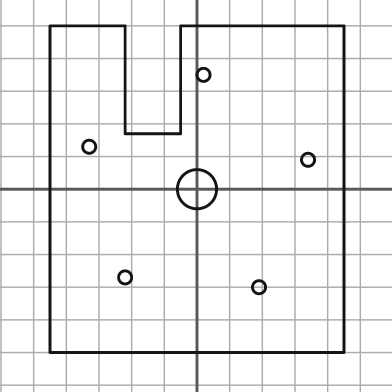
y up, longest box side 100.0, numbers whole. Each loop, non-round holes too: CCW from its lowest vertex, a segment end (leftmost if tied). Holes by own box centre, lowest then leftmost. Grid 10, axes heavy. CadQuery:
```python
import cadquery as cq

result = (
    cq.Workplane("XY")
    .moveTo(-45.0, -50.0)
    .lineTo(45.0, -50.0)
    .lineTo(45.0, 50.0)
    .lineTo(-5.0, 50.0)
    .lineTo(-5.0, 17.0)
    .lineTo(-22.0, 17.0)
    .lineTo(-22.0, 50.0)
    .lineTo(-45.0, 50.0)
    .close()
    .moveTo(19.0, -30.0)
    .circle(2.0)
    .moveTo(-22.0, -27.0)
    .circle(2.0)
    .moveTo(0.0, 0.0)
    .circle(6.0)
    .moveTo(34.0, 9.0)
    .circle(2.0)
    .moveTo(-33.0, 13.0)
    .circle(2.0)
    .moveTo(2.0, 35.0)
    .circle(2.0)
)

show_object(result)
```